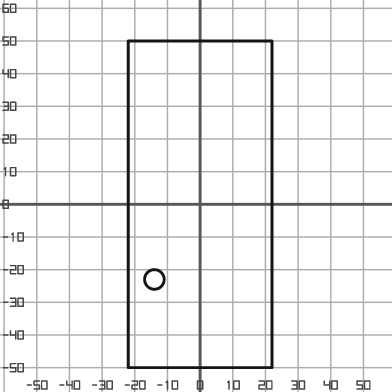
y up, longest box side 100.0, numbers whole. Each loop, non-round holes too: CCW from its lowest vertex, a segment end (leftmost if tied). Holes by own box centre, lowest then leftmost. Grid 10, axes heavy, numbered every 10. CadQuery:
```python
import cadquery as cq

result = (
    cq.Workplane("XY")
    .moveTo(-22.0, -50.0)
    .lineTo(22.0, -50.0)
    .lineTo(22.0, 50.0)
    .lineTo(-22.0, 50.0)
    .close()
    .moveTo(-14.0, -23.0)
    .circle(3.0)
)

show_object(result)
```